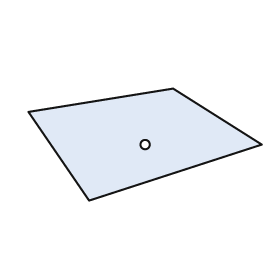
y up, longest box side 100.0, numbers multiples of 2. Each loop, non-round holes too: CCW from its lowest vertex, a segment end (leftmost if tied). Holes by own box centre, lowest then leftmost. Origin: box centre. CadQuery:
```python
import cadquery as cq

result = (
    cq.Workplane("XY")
    .moveTo(-24.0, -24.0)
    .lineTo(50.0, 0.0)
    .lineTo(12.0, 24.0)
    .lineTo(-50.0, 14.0)
    .close()
    .moveTo(0.0, 0.0)
    .circle(2.0)
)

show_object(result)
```